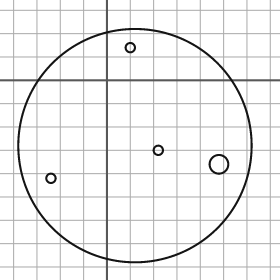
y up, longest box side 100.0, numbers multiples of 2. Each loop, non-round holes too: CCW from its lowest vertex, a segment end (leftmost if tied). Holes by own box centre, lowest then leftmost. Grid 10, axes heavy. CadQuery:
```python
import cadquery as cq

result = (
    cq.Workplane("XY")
    .moveTo(12.0, -28.0)
    .circle(50.0)
    .moveTo(-24.0, -42.0)
    .circle(2.0)
    .moveTo(48.0, -36.0)
    .circle(4.0)
    .moveTo(22.0, -30.0)
    .circle(2.0)
    .moveTo(10.0, 14.0)
    .circle(2.0)
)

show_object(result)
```